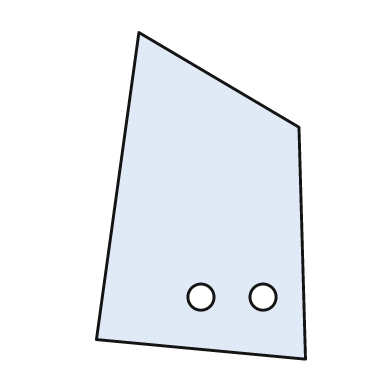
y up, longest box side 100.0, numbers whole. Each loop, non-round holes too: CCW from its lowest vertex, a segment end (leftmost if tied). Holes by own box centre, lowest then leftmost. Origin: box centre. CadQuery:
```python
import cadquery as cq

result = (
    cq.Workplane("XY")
    .moveTo(32.0, -50.0)
    .lineTo(30.0, 21.0)
    .lineTo(-19.0, 50.0)
    .lineTo(-32.0, -44.0)
    .close()
    .moveTo(0.0, -31.0)
    .circle(4.0)
    .moveTo(19.0, -31.0)
    .circle(4.0)
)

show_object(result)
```